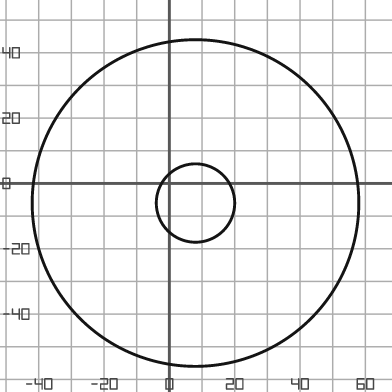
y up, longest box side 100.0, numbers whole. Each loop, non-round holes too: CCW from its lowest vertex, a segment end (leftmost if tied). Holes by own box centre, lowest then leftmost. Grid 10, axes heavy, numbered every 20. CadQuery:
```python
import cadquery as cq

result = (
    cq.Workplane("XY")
    .moveTo(8.0, -6.0)
    .circle(50.0)
    .moveTo(8.0, -6.0)
    .circle(12.0)
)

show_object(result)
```